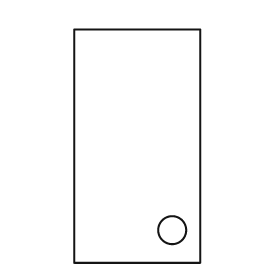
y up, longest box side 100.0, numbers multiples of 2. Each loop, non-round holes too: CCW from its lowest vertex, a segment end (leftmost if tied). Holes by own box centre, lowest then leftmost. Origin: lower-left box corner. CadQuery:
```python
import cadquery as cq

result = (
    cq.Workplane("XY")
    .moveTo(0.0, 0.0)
    .lineTo(54.0, 0.0)
    .lineTo(54.0, 100.0)
    .lineTo(0.0, 100.0)
    .close()
    .moveTo(42.0, 14.0)
    .circle(6.0)
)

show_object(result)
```